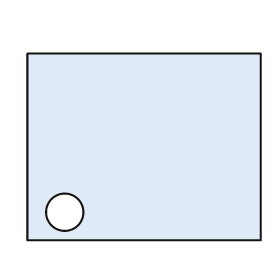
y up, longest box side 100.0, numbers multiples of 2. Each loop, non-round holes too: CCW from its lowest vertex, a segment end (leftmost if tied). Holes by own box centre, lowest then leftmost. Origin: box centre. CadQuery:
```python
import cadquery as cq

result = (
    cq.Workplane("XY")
    .moveTo(-50.0, -40.0)
    .lineTo(50.0, -40.0)
    .lineTo(50.0, 40.0)
    .lineTo(-50.0, 40.0)
    .close()
    .moveTo(-34.0, -28.0)
    .circle(8.0)
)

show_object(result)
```